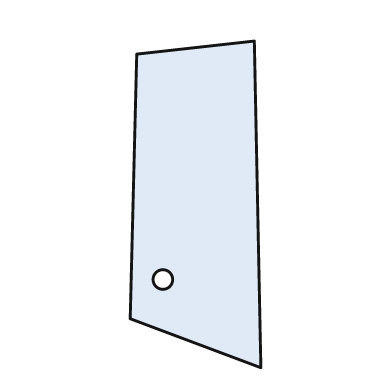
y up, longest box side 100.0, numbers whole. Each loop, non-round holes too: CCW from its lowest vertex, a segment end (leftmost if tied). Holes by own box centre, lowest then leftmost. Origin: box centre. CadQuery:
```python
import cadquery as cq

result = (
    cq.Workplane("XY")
    .moveTo(20.0, -50.0)
    .lineTo(18.0, 50.0)
    .lineTo(-18.0, 46.0)
    .lineTo(-20.0, -35.0)
    .close()
    .moveTo(-10.0, -23.0)
    .circle(3.0)
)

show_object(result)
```